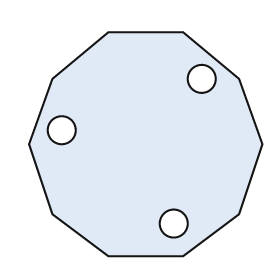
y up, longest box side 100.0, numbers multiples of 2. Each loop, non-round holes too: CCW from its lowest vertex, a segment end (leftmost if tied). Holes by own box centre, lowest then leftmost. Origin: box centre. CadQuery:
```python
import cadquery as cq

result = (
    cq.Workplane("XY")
    .moveTo(-16.0, -48.0)
    .lineTo(16.0, -48.0)
    .lineTo(40.0, -30.0)
    .lineTo(50.0, 0.0)
    .lineTo(40.0, 28.0)
    .lineTo(16.0, 48.0)
    .lineTo(-16.0, 48.0)
    .lineTo(-40.0, 28.0)
    .lineTo(-50.0, 0.0)
    .lineTo(-40.0, -30.0)
    .close()
    .moveTo(12.0, -34.0)
    .circle(6.0)
    .moveTo(-36.0, 6.0)
    .circle(6.0)
    .moveTo(24.0, 28.0)
    .circle(6.0)
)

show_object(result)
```